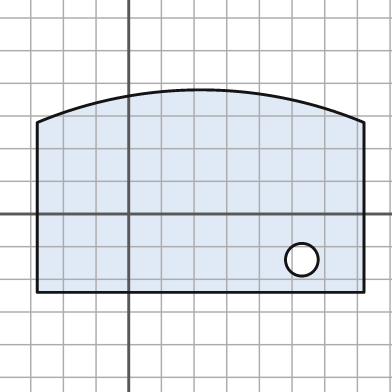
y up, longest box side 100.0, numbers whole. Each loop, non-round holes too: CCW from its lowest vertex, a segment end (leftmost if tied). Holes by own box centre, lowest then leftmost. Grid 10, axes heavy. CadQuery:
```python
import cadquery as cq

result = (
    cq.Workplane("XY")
    .moveTo(-28.0, -24.0)
    .lineTo(72.0, -24.0)
    .lineTo(72.0, 28.0)
    .threePointArc((22.0, 38.0), (-28.0, 28.0))
    .close()
    .moveTo(53.0, -14.0)
    .circle(5.0)
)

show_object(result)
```